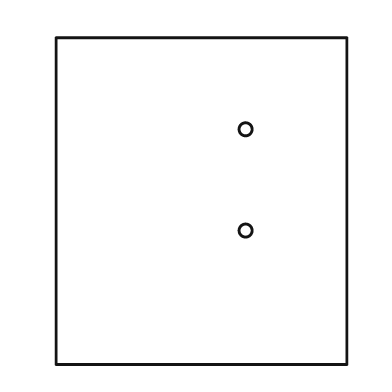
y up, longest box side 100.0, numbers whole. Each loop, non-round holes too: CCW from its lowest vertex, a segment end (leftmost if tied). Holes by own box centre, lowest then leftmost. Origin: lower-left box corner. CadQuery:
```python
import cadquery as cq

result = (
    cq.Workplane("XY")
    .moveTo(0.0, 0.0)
    .lineTo(89.0, 0.0)
    .lineTo(89.0, 100.0)
    .lineTo(0.0, 100.0)
    .close()
    .moveTo(58.0, 41.0)
    .circle(2.0)
    .moveTo(58.0, 72.0)
    .circle(2.0)
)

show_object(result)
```